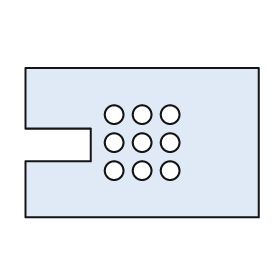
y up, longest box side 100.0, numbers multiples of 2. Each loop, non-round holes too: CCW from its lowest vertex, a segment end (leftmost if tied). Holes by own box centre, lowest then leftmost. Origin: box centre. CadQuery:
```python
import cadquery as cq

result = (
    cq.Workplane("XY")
    .moveTo(-50.0, -32.0)
    .lineTo(50.0, -32.0)
    .lineTo(50.0, 32.0)
    .lineTo(-50.0, 32.0)
    .lineTo(-50.0, 6.0)
    .lineTo(-22.0, 6.0)
    .lineTo(-22.0, -8.0)
    .lineTo(-50.0, -8.0)
    .close()
    .moveTo(-12.0, -12.0)
    .circle(4.0)
    .moveTo(0.0, -12.0)
    .circle(4.0)
    .moveTo(12.0, -12.0)
    .circle(4.0)
    .moveTo(-12.0, 0.0)
    .circle(4.0)
    .moveTo(0.0, 0.0)
    .circle(4.0)
    .moveTo(12.0, 0.0)
    .circle(4.0)
    .moveTo(-12.0, 12.0)
    .circle(4.0)
    .moveTo(0.0, 12.0)
    .circle(4.0)
    .moveTo(12.0, 12.0)
    .circle(4.0)
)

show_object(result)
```